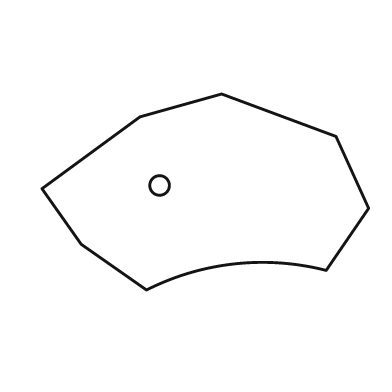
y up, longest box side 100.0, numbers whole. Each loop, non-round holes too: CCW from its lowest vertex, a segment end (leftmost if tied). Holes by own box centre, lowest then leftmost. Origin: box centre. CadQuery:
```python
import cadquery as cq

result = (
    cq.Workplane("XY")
    .moveTo(-18.0, -30.0)
    .threePointArc((9.0, -22.0), (37.0, -24.0))
    .lineTo(50.0, -5.0)
    .lineTo(40.0, 17.0)
    .lineTo(5.0, 30.0)
    .lineTo(-20.0, 23.0)
    .lineTo(-50.0, 1.0)
    .lineTo(-38.0, -16.0)
    .close()
    .moveTo(-14.0, 2.0)
    .circle(3.0)
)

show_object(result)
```